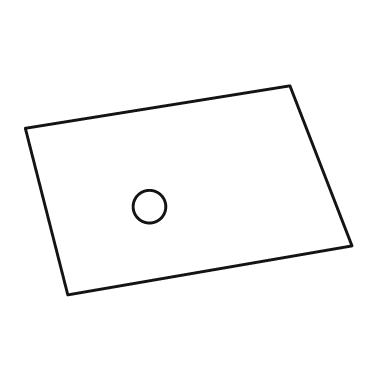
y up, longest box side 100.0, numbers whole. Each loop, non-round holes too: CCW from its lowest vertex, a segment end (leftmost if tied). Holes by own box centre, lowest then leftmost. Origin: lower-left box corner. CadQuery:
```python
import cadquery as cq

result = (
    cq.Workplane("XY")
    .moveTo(13.0, 0.0)
    .lineTo(100.0, 15.0)
    .lineTo(81.0, 64.0)
    .lineTo(0.0, 51.0)
    .close()
    .moveTo(38.0, 27.0)
    .circle(5.0)
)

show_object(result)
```